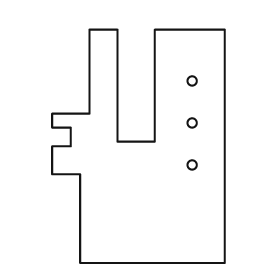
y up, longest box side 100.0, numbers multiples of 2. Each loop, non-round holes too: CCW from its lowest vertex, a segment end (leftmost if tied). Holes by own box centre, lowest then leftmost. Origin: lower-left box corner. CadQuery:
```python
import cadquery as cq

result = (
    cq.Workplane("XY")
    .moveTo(12.0, 0.0)
    .lineTo(74.0, 0.0)
    .lineTo(74.0, 100.0)
    .lineTo(44.0, 100.0)
    .lineTo(44.0, 52.0)
    .lineTo(28.0, 52.0)
    .lineTo(28.0, 100.0)
    .lineTo(16.0, 100.0)
    .lineTo(16.0, 64.0)
    .lineTo(0.0, 64.0)
    .lineTo(0.0, 58.0)
    .lineTo(8.0, 58.0)
    .lineTo(8.0, 50.0)
    .lineTo(0.0, 50.0)
    .lineTo(0.0, 38.0)
    .lineTo(12.0, 38.0)
    .close()
    .moveTo(60.0, 42.0)
    .circle(2.0)
    .moveTo(60.0, 60.0)
    .circle(2.0)
    .moveTo(60.0, 78.0)
    .circle(2.0)
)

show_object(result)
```